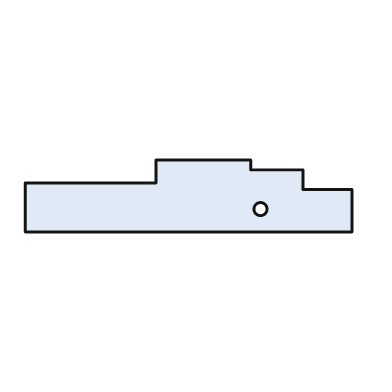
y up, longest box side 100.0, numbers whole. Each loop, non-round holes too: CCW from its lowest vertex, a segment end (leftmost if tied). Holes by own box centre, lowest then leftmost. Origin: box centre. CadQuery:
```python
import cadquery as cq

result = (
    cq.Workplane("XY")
    .moveTo(-50.0, -11.0)
    .lineTo(50.0, -11.0)
    .lineTo(50.0, 2.0)
    .lineTo(35.0, 2.0)
    .lineTo(35.0, 8.0)
    .lineTo(19.0, 8.0)
    .lineTo(19.0, 11.0)
    .lineTo(-10.0, 11.0)
    .lineTo(-10.0, 4.0)
    .lineTo(-50.0, 4.0)
    .close()
    .moveTo(22.0, -4.0)
    .circle(2.0)
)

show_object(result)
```